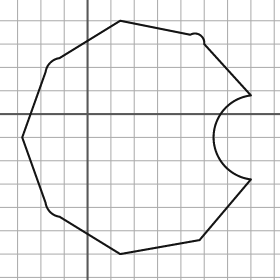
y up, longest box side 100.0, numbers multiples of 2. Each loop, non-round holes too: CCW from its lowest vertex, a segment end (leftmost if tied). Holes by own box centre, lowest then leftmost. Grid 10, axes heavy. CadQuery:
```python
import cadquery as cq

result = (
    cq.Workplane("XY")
    .moveTo(14.0, -60.0)
    .lineTo(48.0, -54.0)
    .lineTo(70.0, -28.0)
    .threePointArc((54.0, -10.0), (70.0, 8.0))
    .lineTo(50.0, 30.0)
    .threePointArc((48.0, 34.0), (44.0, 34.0))
    .lineTo(14.0, 40.0)
    .lineTo(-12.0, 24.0)
    .threePointArc((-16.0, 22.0), (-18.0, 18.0))
    .lineTo(-28.0, -10.0)
    .lineTo(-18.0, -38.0)
    .threePointArc((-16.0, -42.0), (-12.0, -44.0))
    .close()
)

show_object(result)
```